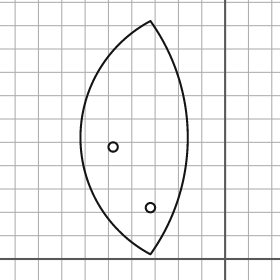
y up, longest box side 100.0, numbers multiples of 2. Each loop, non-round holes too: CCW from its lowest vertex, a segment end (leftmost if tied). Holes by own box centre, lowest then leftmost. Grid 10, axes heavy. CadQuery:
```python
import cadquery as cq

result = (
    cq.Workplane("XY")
    .moveTo(-32.0, 2.0)
    .threePointArc((-16.0, 52.0), (-32.0, 102.0))
    .threePointArc((-62.0, 52.0), (-32.0, 2.0))
    .close()
    .moveTo(-32.0, 22.0)
    .circle(2.0)
    .moveTo(-48.0, 48.0)
    .circle(2.0)
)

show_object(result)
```